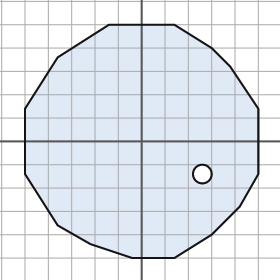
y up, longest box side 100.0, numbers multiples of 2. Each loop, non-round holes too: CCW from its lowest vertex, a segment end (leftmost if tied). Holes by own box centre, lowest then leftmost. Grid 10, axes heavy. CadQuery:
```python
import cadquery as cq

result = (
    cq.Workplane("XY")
    .moveTo(-4.0, -50.0)
    .lineTo(14.0, -50.0)
    .lineTo(30.0, -40.0)
    .lineTo(42.0, -28.0)
    .lineTo(50.0, -14.0)
    .lineTo(50.0, 14.0)
    .lineTo(38.0, 32.0)
    .lineTo(30.0, 40.0)
    .lineTo(14.0, 50.0)
    .lineTo(-14.0, 50.0)
    .lineTo(-36.0, 36.0)
    .lineTo(-50.0, 14.0)
    .lineTo(-50.0, -14.0)
    .lineTo(-36.0, -36.0)
    .lineTo(-22.0, -44.0)
    .close()
    .moveTo(26.0, -14.0)
    .circle(4.0)
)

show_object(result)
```